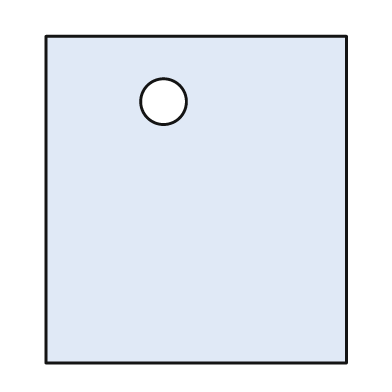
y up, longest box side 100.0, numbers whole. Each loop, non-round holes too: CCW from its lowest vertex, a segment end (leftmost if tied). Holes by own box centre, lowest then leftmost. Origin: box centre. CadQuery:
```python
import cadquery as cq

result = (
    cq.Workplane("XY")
    .moveTo(-46.0, -50.0)
    .lineTo(46.0, -50.0)
    .lineTo(46.0, 50.0)
    .lineTo(-46.0, 50.0)
    .close()
    .moveTo(-10.0, 30.0)
    .circle(7.0)
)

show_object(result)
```